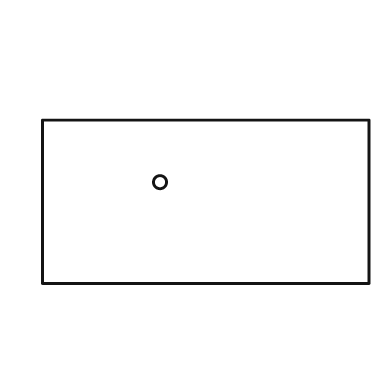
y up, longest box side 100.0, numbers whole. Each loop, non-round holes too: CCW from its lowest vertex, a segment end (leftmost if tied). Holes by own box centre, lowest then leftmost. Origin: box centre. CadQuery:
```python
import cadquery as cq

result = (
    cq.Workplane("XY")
    .moveTo(-50.0, -25.0)
    .lineTo(50.0, -25.0)
    .lineTo(50.0, 25.0)
    .lineTo(-50.0, 25.0)
    .close()
    .moveTo(-14.0, 6.0)
    .circle(2.0)
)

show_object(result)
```